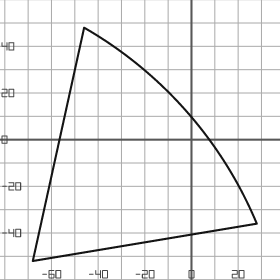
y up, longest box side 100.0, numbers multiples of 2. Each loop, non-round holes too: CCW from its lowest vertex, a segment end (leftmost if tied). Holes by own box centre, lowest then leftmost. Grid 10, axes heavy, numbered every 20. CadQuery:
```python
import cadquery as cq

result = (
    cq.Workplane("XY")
    .moveTo(-68.0, -52.0)
    .lineTo(28.0, -36.0)
    .threePointArc((-2.0, 12.0), (-46.0, 48.0))
    .close()
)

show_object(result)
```